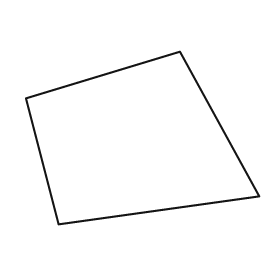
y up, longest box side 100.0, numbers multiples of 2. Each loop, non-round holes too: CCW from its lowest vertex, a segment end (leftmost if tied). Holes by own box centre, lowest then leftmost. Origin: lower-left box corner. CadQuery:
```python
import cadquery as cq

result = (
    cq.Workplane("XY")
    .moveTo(14.0, 0.0)
    .lineTo(100.0, 12.0)
    .lineTo(66.0, 74.0)
    .lineTo(0.0, 54.0)
    .close()
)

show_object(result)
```